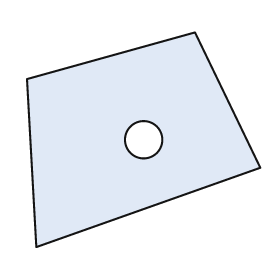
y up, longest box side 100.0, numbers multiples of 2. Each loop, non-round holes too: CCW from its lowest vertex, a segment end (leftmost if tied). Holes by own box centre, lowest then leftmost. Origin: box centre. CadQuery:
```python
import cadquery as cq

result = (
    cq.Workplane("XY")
    .moveTo(-46.0, -46.0)
    .lineTo(50.0, -12.0)
    .lineTo(22.0, 46.0)
    .lineTo(-50.0, 26.0)
    .close()
    .moveTo(0.0, 0.0)
    .circle(8.0)
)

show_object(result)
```